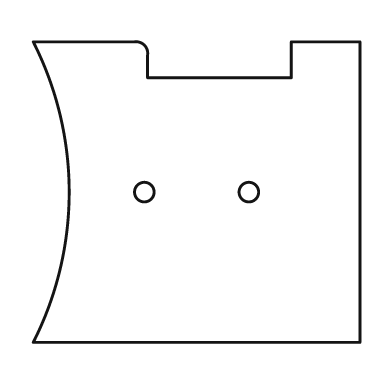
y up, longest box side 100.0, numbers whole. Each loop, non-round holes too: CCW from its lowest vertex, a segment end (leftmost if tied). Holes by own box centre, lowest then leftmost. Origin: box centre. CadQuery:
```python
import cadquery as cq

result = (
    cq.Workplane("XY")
    .moveTo(-50.0, -46.0)
    .lineTo(50.0, -46.0)
    .lineTo(50.0, 46.0)
    .lineTo(29.0, 46.0)
    .lineTo(29.0, 35.0)
    .lineTo(-15.0, 35.0)
    .lineTo(-15.0, 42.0)
    .threePointArc((-16.0, 45.0), (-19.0, 46.0))
    .lineTo(-50.0, 46.0)
    .threePointArc((-39.0, 0.0), (-50.0, -46.0))
    .close()
    .moveTo(-16.0, 0.0)
    .circle(3.0)
    .moveTo(16.0, 0.0)
    .circle(3.0)
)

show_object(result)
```